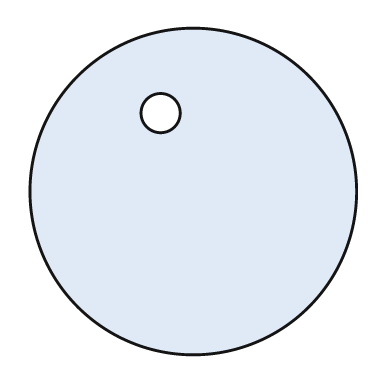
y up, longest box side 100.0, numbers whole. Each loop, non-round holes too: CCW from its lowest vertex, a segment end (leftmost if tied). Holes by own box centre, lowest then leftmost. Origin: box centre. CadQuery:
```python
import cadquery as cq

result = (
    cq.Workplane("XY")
    .moveTo(0.0, 0.0)
    .circle(50.0)
    .moveTo(-10.0, 24.0)
    .circle(6.0)
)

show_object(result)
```